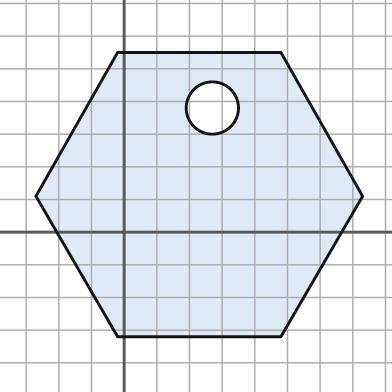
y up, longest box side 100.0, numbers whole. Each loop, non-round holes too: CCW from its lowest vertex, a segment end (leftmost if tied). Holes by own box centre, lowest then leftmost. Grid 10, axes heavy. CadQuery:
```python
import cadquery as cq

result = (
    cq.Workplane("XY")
    .moveTo(-2.0, -32.0)
    .lineTo(48.0, -32.0)
    .lineTo(73.0, 11.0)
    .lineTo(48.0, 55.0)
    .lineTo(-2.0, 55.0)
    .lineTo(-27.0, 11.0)
    .close()
    .moveTo(27.0, 38.0)
    .circle(8.0)
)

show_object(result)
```